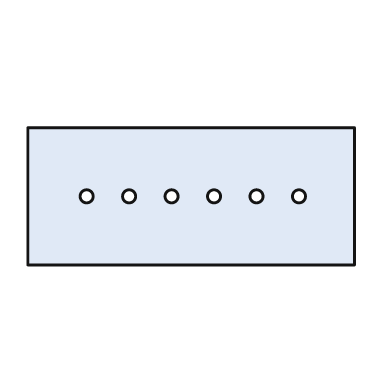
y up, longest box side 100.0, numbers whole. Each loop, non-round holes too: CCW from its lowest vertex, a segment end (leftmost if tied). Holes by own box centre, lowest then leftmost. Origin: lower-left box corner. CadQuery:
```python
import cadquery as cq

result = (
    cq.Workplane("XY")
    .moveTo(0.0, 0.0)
    .lineTo(100.0, 0.0)
    .lineTo(100.0, 42.0)
    .lineTo(0.0, 42.0)
    .close()
    .moveTo(18.0, 21.0)
    .circle(2.0)
    .moveTo(31.0, 21.0)
    .circle(2.0)
    .moveTo(44.0, 21.0)
    .circle(2.0)
    .moveTo(57.0, 21.0)
    .circle(2.0)
    .moveTo(70.0, 21.0)
    .circle(2.0)
    .moveTo(83.0, 21.0)
    .circle(2.0)
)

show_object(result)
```